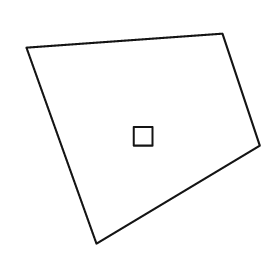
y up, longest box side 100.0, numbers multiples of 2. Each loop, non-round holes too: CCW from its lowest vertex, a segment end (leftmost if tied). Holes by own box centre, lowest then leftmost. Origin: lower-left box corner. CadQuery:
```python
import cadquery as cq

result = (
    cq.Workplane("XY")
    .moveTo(30.0, 0.0)
    .lineTo(100.0, 42.0)
    .lineTo(84.0, 90.0)
    .lineTo(0.0, 84.0)
    .close()
    .moveTo(46.0, 42.0)
    .lineTo(54.0, 42.0)
    .lineTo(54.0, 50.0)
    .lineTo(46.0, 50.0)
    .close()
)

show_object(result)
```